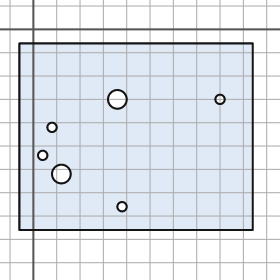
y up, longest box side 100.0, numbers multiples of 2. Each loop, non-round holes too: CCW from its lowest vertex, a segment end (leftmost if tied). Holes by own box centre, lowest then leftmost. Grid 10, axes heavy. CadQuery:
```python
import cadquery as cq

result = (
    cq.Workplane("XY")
    .moveTo(-6.0, -86.0)
    .lineTo(94.0, -86.0)
    .lineTo(94.0, -6.0)
    .lineTo(-6.0, -6.0)
    .close()
    .moveTo(38.0, -76.0)
    .circle(2.0)
    .moveTo(12.0, -62.0)
    .circle(4.0)
    .moveTo(4.0, -54.0)
    .circle(2.0)
    .moveTo(8.0, -42.0)
    .circle(2.0)
    .moveTo(36.0, -30.0)
    .circle(4.0)
    .moveTo(80.0, -30.0)
    .circle(2.0)
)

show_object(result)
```